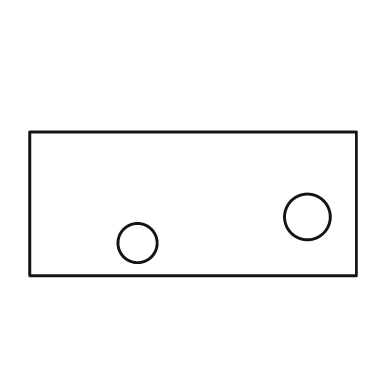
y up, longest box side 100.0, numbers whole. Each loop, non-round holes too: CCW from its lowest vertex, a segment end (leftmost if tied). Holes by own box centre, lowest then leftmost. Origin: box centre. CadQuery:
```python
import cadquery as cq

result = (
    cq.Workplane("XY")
    .moveTo(-50.0, -22.0)
    .lineTo(50.0, -22.0)
    .lineTo(50.0, 22.0)
    .lineTo(-50.0, 22.0)
    .close()
    .moveTo(-17.0, -12.0)
    .circle(6.0)
    .moveTo(35.0, -4.0)
    .circle(7.0)
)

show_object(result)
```